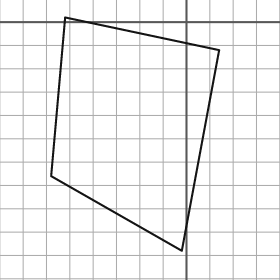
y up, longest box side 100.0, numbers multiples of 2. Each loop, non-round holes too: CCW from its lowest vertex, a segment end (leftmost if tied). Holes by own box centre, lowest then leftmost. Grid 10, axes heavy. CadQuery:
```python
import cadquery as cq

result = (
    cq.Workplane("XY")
    .moveTo(-2.0, -98.0)
    .lineTo(14.0, -12.0)
    .lineTo(-52.0, 2.0)
    .lineTo(-58.0, -66.0)
    .close()
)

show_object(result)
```